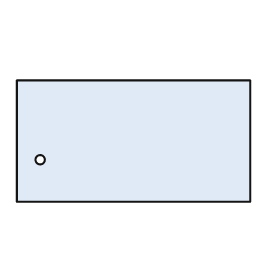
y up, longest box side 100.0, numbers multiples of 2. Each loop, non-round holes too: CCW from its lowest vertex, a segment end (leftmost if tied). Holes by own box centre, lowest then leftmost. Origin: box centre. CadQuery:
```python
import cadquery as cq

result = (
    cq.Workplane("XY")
    .moveTo(-50.0, -26.0)
    .lineTo(50.0, -26.0)
    .lineTo(50.0, 26.0)
    .lineTo(-50.0, 26.0)
    .close()
    .moveTo(-40.0, -8.0)
    .circle(2.0)
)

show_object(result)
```